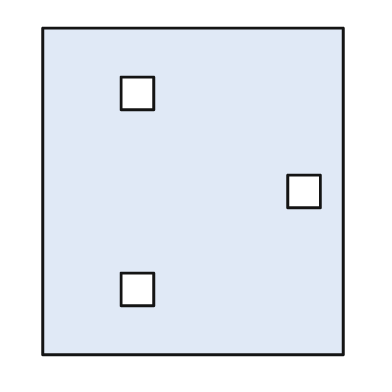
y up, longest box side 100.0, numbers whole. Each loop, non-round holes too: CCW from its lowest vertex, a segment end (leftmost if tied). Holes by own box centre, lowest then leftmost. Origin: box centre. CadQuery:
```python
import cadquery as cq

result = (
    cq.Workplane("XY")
    .moveTo(-46.0, -50.0)
    .lineTo(46.0, -50.0)
    .lineTo(46.0, 50.0)
    .lineTo(-46.0, 50.0)
    .close()
    .moveTo(-22.0, -35.0)
    .lineTo(-12.0, -35.0)
    .lineTo(-12.0, -25.0)
    .lineTo(-22.0, -25.0)
    .close()
    .moveTo(29.0, -5.0)
    .lineTo(39.0, -5.0)
    .lineTo(39.0, 5.0)
    .lineTo(29.0, 5.0)
    .close()
    .moveTo(-22.0, 25.0)
    .lineTo(-12.0, 25.0)
    .lineTo(-12.0, 35.0)
    .lineTo(-22.0, 35.0)
    .close()
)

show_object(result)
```